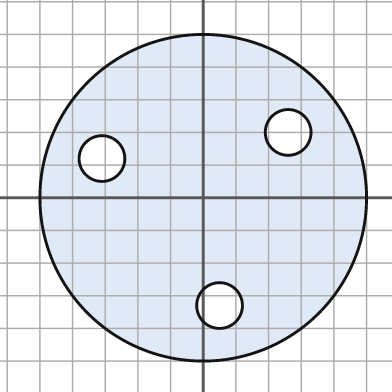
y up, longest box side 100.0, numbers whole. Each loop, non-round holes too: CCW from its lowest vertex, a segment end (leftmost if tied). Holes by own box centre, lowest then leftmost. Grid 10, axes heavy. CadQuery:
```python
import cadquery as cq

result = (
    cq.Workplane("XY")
    .moveTo(0.0, 0.0)
    .circle(50.0)
    .moveTo(5.0, -33.0)
    .circle(7.0)
    .moveTo(-31.0, 12.0)
    .circle(7.0)
    .moveTo(26.0, 20.0)
    .circle(7.0)
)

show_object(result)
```